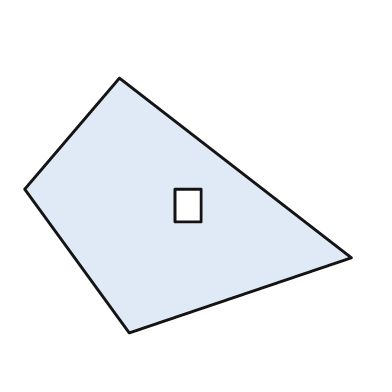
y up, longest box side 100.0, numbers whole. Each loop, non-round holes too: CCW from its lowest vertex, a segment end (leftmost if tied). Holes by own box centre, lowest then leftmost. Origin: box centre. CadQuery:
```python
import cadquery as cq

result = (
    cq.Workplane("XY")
    .moveTo(-18.0, -39.0)
    .lineTo(50.0, -16.0)
    .lineTo(-21.0, 39.0)
    .lineTo(-50.0, 5.0)
    .close()
    .moveTo(-4.0, -5.0)
    .lineTo(4.0, -5.0)
    .lineTo(4.0, 5.0)
    .lineTo(-4.0, 5.0)
    .close()
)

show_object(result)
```